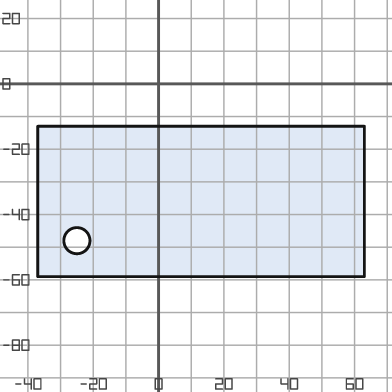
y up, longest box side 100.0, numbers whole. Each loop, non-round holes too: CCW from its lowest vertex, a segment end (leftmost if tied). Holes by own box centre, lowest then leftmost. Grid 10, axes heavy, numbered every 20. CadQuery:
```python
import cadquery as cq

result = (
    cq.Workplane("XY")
    .moveTo(-37.0, -59.0)
    .lineTo(63.0, -59.0)
    .lineTo(63.0, -13.0)
    .lineTo(-37.0, -13.0)
    .close()
    .moveTo(-25.0, -48.0)
    .circle(4.0)
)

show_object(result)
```